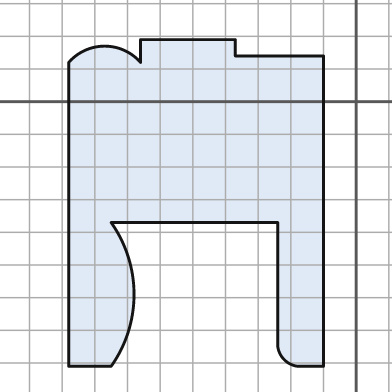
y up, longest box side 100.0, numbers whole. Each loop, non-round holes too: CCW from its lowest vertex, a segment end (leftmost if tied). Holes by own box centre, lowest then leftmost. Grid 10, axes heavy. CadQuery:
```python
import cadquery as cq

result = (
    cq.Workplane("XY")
    .moveTo(-88.0, -81.0)
    .lineTo(-75.0, -81.0)
    .threePointArc((-68.0, -59.0), (-75.0, -37.0))
    .lineTo(-24.0, -37.0)
    .lineTo(-24.0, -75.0)
    .threePointArc((-22.0, -79.0), (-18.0, -81.0))
    .lineTo(-10.0, -81.0)
    .lineTo(-10.0, 14.0)
    .lineTo(-37.0, 14.0)
    .lineTo(-37.0, 19.0)
    .lineTo(-66.0, 19.0)
    .lineTo(-66.0, 12.0)
    .threePointArc((-77.0, 17.0), (-88.0, 12.0))
    .close()
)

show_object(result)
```